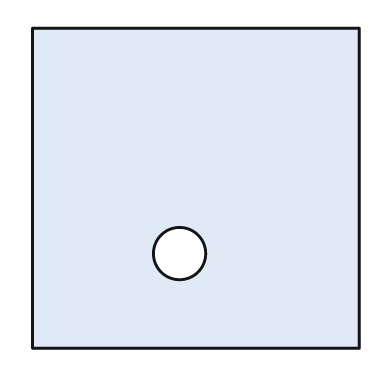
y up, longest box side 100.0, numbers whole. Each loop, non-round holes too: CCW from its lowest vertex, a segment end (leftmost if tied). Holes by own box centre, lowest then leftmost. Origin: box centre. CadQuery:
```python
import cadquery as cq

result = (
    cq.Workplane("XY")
    .moveTo(-50.0, -49.0)
    .lineTo(50.0, -49.0)
    .lineTo(50.0, 49.0)
    .lineTo(-50.0, 49.0)
    .close()
    .moveTo(-5.0, -20.0)
    .circle(8.0)
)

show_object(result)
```